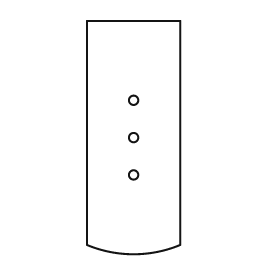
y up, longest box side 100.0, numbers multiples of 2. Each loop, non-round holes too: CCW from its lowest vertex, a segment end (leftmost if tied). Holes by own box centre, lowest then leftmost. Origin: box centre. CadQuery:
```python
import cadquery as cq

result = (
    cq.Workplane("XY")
    .moveTo(-20.0, -46.0)
    .threePointArc((0.0, -50.0), (20.0, -46.0))
    .lineTo(20.0, 50.0)
    .lineTo(-20.0, 50.0)
    .close()
    .moveTo(0.0, -16.0)
    .circle(2.0)
    .moveTo(0.0, 0.0)
    .circle(2.0)
    .moveTo(0.0, 16.0)
    .circle(2.0)
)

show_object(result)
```